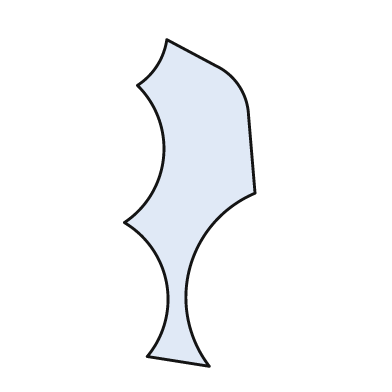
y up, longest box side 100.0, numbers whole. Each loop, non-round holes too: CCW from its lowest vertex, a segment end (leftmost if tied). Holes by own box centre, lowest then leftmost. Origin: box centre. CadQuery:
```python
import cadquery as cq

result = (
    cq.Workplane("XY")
    .moveTo(6.0, -50.0)
    .threePointArc((0.0, -20.0), (20.0, 3.0))
    .lineTo(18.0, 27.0)
    .threePointArc((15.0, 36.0), (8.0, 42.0))
    .lineTo(-7.0, 50.0)
    .threePointArc((-10.0, 42.0), (-16.0, 36.0))
    .threePointArc((-8.0, 14.0), (-20.0, -6.0))
    .threePointArc((-7.0, -25.0), (-13.0, -47.0))
    .close()
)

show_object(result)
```